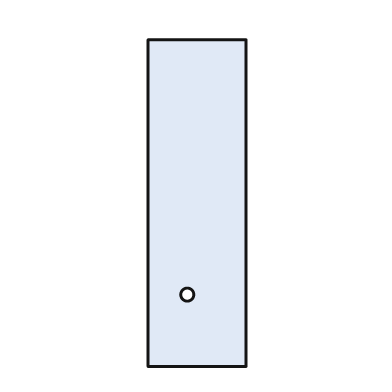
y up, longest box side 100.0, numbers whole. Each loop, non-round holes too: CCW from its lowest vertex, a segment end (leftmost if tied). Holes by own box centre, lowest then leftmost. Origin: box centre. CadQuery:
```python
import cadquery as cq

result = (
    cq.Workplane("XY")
    .moveTo(-15.0, -50.0)
    .lineTo(15.0, -50.0)
    .lineTo(15.0, 50.0)
    .lineTo(-15.0, 50.0)
    .close()
    .moveTo(-3.0, -28.0)
    .circle(2.0)
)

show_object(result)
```